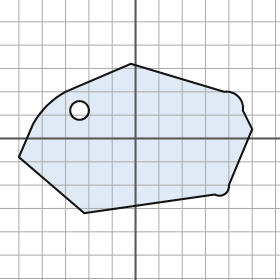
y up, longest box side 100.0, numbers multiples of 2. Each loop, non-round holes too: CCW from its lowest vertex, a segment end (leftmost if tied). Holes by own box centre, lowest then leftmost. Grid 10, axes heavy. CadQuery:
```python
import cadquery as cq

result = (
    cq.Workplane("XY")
    .moveTo(-22.0, -32.0)
    .lineTo(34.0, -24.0)
    .threePointArc((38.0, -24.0), (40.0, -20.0))
    .lineTo(50.0, 4.0)
    .lineTo(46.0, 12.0)
    .threePointArc((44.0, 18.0), (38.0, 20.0))
    .lineTo(-2.0, 32.0)
    .lineTo(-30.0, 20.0)
    .threePointArc((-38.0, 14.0), (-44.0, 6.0))
    .lineTo(-50.0, -8.0)
    .close()
    .moveTo(-24.0, 12.0)
    .circle(4.0)
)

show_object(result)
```